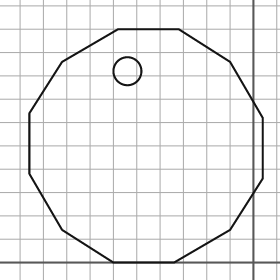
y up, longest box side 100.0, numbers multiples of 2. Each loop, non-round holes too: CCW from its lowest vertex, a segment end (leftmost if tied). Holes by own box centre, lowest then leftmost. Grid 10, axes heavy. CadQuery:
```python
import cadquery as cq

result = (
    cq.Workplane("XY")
    .moveTo(-60.0, 0.0)
    .lineTo(-34.0, 0.0)
    .lineTo(-10.0, 14.0)
    .lineTo(4.0, 36.0)
    .lineTo(4.0, 62.0)
    .lineTo(-10.0, 86.0)
    .lineTo(-32.0, 100.0)
    .lineTo(-58.0, 100.0)
    .lineTo(-82.0, 86.0)
    .lineTo(-96.0, 64.0)
    .lineTo(-96.0, 38.0)
    .lineTo(-82.0, 14.0)
    .close()
    .moveTo(-54.0, 82.0)
    .circle(6.0)
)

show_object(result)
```